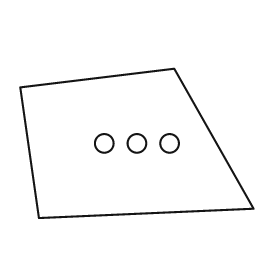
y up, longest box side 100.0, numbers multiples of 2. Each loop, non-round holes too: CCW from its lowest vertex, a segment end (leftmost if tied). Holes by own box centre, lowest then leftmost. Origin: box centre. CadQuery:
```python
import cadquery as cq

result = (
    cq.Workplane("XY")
    .moveTo(-42.0, -32.0)
    .lineTo(50.0, -28.0)
    .lineTo(16.0, 32.0)
    .lineTo(-50.0, 24.0)
    .close()
    .moveTo(-14.0, 0.0)
    .circle(4.0)
    .moveTo(0.0, 0.0)
    .circle(4.0)
    .moveTo(14.0, 0.0)
    .circle(4.0)
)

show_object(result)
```